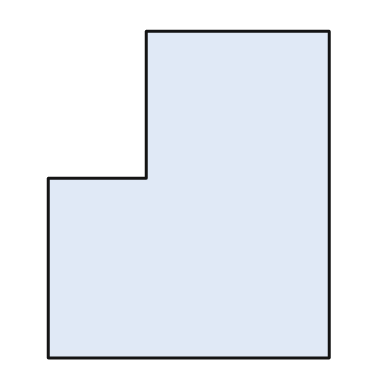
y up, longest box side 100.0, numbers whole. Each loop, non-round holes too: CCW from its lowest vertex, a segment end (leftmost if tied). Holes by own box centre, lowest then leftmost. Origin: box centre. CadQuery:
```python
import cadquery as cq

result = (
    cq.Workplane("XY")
    .moveTo(-43.0, -50.0)
    .lineTo(43.0, -50.0)
    .lineTo(43.0, 50.0)
    .lineTo(-13.0, 50.0)
    .lineTo(-13.0, 5.0)
    .lineTo(-43.0, 5.0)
    .close()
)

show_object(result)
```